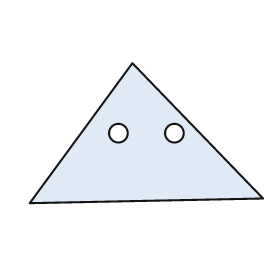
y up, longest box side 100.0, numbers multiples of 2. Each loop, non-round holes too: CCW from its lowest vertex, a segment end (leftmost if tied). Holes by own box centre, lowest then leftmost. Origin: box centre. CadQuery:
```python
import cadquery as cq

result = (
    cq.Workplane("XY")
    .moveTo(-50.0, -30.0)
    .lineTo(50.0, -28.0)
    .lineTo(-6.0, 30.0)
    .close()
    .moveTo(-12.0, 0.0)
    .circle(4.0)
    .moveTo(12.0, 0.0)
    .circle(4.0)
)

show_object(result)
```